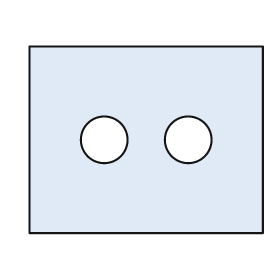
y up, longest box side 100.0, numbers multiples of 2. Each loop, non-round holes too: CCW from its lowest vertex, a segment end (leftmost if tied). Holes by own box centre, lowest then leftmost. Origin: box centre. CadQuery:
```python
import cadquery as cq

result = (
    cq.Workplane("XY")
    .moveTo(-50.0, -40.0)
    .lineTo(50.0, -40.0)
    .lineTo(50.0, 40.0)
    .lineTo(-50.0, 40.0)
    .close()
    .moveTo(-18.0, 0.0)
    .circle(10.0)
    .moveTo(18.0, 0.0)
    .circle(10.0)
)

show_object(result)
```